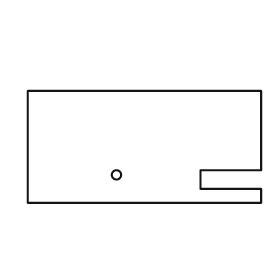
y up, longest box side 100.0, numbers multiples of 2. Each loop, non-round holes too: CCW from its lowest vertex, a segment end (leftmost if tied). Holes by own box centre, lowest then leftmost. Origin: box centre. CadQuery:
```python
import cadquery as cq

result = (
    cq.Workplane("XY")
    .moveTo(-50.0, -24.0)
    .lineTo(50.0, -24.0)
    .lineTo(50.0, -18.0)
    .lineTo(24.0, -18.0)
    .lineTo(24.0, -10.0)
    .lineTo(50.0, -10.0)
    .lineTo(50.0, 24.0)
    .lineTo(-50.0, 24.0)
    .close()
    .moveTo(-12.0, -12.0)
    .circle(2.0)
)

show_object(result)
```